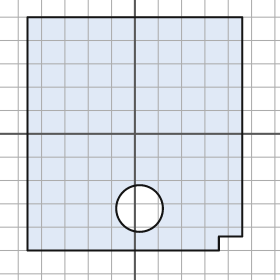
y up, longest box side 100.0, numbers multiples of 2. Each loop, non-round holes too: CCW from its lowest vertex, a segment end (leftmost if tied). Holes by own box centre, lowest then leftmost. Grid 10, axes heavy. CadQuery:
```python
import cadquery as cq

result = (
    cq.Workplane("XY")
    .moveTo(-46.0, -50.0)
    .lineTo(36.0, -50.0)
    .lineTo(36.0, -44.0)
    .lineTo(46.0, -44.0)
    .lineTo(46.0, 50.0)
    .lineTo(-46.0, 50.0)
    .close()
    .moveTo(2.0, -32.0)
    .circle(10.0)
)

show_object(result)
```